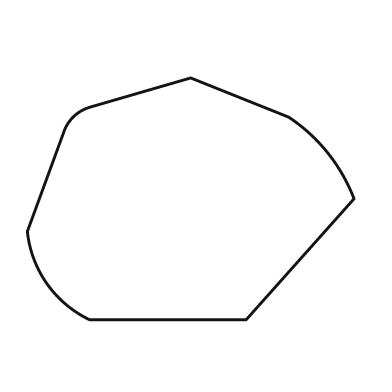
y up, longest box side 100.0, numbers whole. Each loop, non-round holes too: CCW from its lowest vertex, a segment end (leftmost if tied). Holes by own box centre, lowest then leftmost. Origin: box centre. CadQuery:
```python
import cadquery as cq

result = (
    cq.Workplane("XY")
    .moveTo(-31.0, -37.0)
    .lineTo(17.0, -37.0)
    .lineTo(50.0, 0.0)
    .threePointArc((42.0, 14.0), (30.0, 25.0))
    .lineTo(0.0, 37.0)
    .lineTo(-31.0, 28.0)
    .threePointArc((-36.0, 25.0), (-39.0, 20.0))
    .lineTo(-50.0, -10.0)
    .threePointArc((-44.0, -26.0), (-31.0, -37.0))
    .close()
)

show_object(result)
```